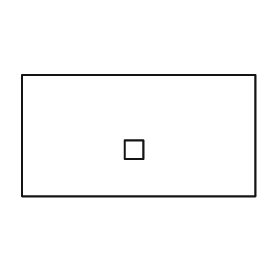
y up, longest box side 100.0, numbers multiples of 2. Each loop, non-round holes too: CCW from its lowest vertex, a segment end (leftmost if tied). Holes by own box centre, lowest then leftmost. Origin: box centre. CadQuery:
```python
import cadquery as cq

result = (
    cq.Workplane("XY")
    .moveTo(-50.0, -26.0)
    .lineTo(50.0, -26.0)
    .lineTo(50.0, 26.0)
    .lineTo(-50.0, 26.0)
    .close()
    .moveTo(-6.0, -10.0)
    .lineTo(2.0, -10.0)
    .lineTo(2.0, -2.0)
    .lineTo(-6.0, -2.0)
    .close()
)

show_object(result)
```